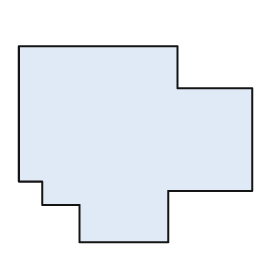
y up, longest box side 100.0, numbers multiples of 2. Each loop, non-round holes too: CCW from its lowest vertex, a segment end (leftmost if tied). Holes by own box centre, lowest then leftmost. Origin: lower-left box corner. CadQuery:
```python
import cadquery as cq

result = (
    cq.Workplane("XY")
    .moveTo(26.0, 0.0)
    .lineTo(64.0, 0.0)
    .lineTo(64.0, 22.0)
    .lineTo(100.0, 22.0)
    .lineTo(100.0, 66.0)
    .lineTo(68.0, 66.0)
    .lineTo(68.0, 84.0)
    .lineTo(0.0, 84.0)
    .lineTo(0.0, 26.0)
    .lineTo(10.0, 26.0)
    .lineTo(10.0, 16.0)
    .lineTo(26.0, 16.0)
    .close()
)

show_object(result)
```